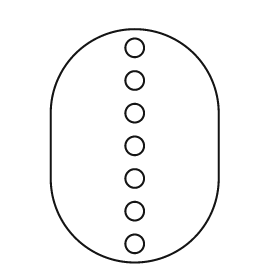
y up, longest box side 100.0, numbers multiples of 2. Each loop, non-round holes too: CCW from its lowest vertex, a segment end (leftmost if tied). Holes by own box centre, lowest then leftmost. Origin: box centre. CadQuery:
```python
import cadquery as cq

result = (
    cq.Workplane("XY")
    .moveTo(-36.0, -14.0)
    .threePointArc((0.0, -50.0), (36.0, -14.0))
    .lineTo(36.0, 14.0)
    .threePointArc((0.0, 50.0), (-36.0, 14.0))
    .close()
    .moveTo(0.0, -42.0)
    .circle(4.0)
    .moveTo(0.0, -28.0)
    .circle(4.0)
    .moveTo(0.0, -14.0)
    .circle(4.0)
    .moveTo(0.0, 0.0)
    .circle(4.0)
    .moveTo(0.0, 14.0)
    .circle(4.0)
    .moveTo(0.0, 28.0)
    .circle(4.0)
    .moveTo(0.0, 42.0)
    .circle(4.0)
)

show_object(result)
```